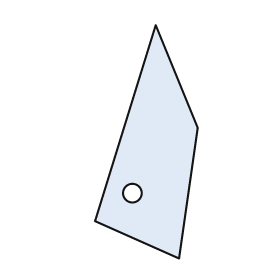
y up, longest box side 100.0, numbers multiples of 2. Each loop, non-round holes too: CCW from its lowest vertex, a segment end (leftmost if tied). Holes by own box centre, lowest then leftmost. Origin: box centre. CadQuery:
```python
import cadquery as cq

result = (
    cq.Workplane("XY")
    .moveTo(14.0, -50.0)
    .lineTo(22.0, 6.0)
    .lineTo(4.0, 50.0)
    .lineTo(-22.0, -34.0)
    .close()
    .moveTo(-6.0, -22.0)
    .circle(4.0)
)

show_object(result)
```